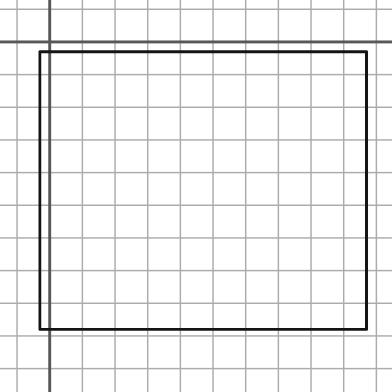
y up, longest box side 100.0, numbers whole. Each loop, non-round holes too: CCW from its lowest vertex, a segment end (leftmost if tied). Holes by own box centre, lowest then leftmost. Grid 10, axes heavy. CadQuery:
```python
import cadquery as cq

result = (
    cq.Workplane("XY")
    .moveTo(-3.0, -88.0)
    .lineTo(97.0, -88.0)
    .lineTo(97.0, -3.0)
    .lineTo(-3.0, -3.0)
    .close()
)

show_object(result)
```